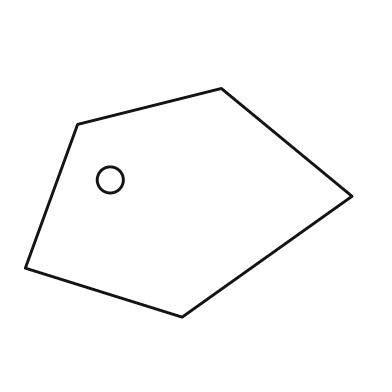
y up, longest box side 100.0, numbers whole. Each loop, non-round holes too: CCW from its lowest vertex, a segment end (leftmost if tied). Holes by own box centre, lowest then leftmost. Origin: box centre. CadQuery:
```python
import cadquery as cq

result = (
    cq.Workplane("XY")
    .moveTo(-2.0, -35.0)
    .lineTo(50.0, 2.0)
    .lineTo(10.0, 35.0)
    .lineTo(-34.0, 24.0)
    .lineTo(-50.0, -20.0)
    .close()
    .moveTo(-24.0, 7.0)
    .circle(4.0)
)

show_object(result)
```